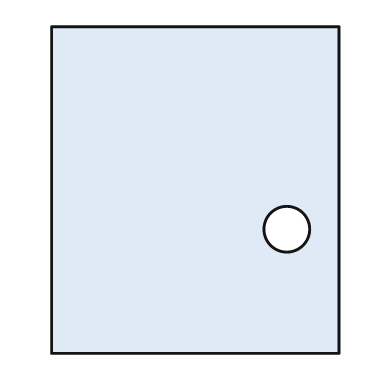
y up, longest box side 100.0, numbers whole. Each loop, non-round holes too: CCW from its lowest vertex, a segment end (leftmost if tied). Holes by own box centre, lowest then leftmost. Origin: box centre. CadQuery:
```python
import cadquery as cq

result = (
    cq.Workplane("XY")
    .moveTo(-44.0, -50.0)
    .lineTo(44.0, -50.0)
    .lineTo(44.0, 50.0)
    .lineTo(-44.0, 50.0)
    .close()
    .moveTo(28.0, -12.0)
    .circle(7.0)
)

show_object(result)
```